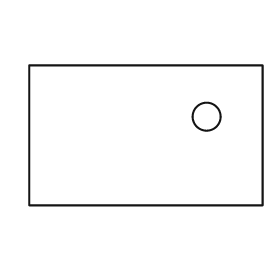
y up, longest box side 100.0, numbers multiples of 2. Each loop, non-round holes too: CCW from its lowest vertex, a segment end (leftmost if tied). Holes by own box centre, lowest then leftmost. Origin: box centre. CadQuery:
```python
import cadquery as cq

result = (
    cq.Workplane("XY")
    .moveTo(-50.0, -30.0)
    .lineTo(50.0, -30.0)
    .lineTo(50.0, 30.0)
    .lineTo(-50.0, 30.0)
    .close()
    .moveTo(26.0, 8.0)
    .circle(6.0)
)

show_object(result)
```